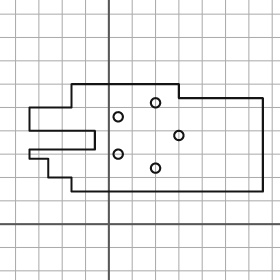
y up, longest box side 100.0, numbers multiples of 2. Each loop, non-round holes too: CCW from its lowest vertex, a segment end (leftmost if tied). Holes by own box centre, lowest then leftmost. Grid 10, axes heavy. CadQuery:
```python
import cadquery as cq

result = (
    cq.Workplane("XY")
    .moveTo(-16.0, 14.0)
    .lineTo(66.0, 14.0)
    .lineTo(66.0, 54.0)
    .lineTo(30.0, 54.0)
    .lineTo(30.0, 60.0)
    .lineTo(-16.0, 60.0)
    .lineTo(-16.0, 50.0)
    .lineTo(-34.0, 50.0)
    .lineTo(-34.0, 40.0)
    .lineTo(-6.0, 40.0)
    .lineTo(-6.0, 32.0)
    .lineTo(-34.0, 32.0)
    .lineTo(-34.0, 28.0)
    .lineTo(-26.0, 28.0)
    .lineTo(-26.0, 20.0)
    .lineTo(-16.0, 20.0)
    .close()
    .moveTo(20.0, 24.0)
    .circle(2.0)
    .moveTo(4.0, 30.0)
    .circle(2.0)
    .moveTo(30.0, 38.0)
    .circle(2.0)
    .moveTo(4.0, 46.0)
    .circle(2.0)
    .moveTo(20.0, 52.0)
    .circle(2.0)
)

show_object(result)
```